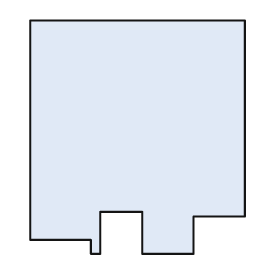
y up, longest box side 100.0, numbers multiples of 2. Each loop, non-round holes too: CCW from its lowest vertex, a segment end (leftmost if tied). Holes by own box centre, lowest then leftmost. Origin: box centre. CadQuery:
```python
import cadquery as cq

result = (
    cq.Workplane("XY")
    .moveTo(-20.0, -50.0)
    .lineTo(-16.0, -50.0)
    .lineTo(-16.0, -32.0)
    .lineTo(2.0, -32.0)
    .lineTo(2.0, -50.0)
    .lineTo(24.0, -50.0)
    .lineTo(24.0, -34.0)
    .lineTo(46.0, -34.0)
    .lineTo(46.0, 50.0)
    .lineTo(-46.0, 50.0)
    .lineTo(-46.0, -44.0)
    .lineTo(-20.0, -44.0)
    .close()
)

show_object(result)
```